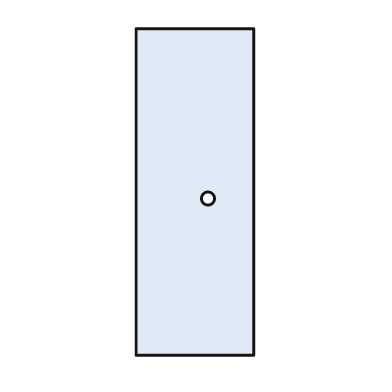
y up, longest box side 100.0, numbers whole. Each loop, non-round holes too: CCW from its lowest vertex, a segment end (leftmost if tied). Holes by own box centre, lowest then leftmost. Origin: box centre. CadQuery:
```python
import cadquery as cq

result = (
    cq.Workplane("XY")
    .moveTo(-18.0, -50.0)
    .lineTo(18.0, -50.0)
    .lineTo(18.0, 50.0)
    .lineTo(-18.0, 50.0)
    .close()
    .moveTo(4.0, -2.0)
    .circle(2.0)
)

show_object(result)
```